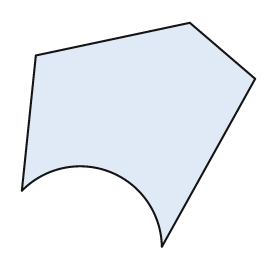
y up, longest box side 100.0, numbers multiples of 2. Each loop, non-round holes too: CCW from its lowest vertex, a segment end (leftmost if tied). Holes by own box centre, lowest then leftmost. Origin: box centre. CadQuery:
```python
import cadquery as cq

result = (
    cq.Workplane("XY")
    .moveTo(10.0, -48.0)
    .lineTo(50.0, 24.0)
    .lineTo(22.0, 48.0)
    .lineTo(-44.0, 34.0)
    .lineTo(-50.0, -24.0)
    .threePointArc((-12.0, -16.0), (10.0, -48.0))
    .close()
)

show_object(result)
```